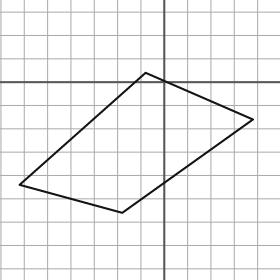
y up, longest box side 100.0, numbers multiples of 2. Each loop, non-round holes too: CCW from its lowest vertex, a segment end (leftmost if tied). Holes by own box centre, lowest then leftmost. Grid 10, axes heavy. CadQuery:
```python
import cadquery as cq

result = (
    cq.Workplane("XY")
    .moveTo(-18.0, -56.0)
    .lineTo(38.0, -16.0)
    .lineTo(-8.0, 4.0)
    .lineTo(-62.0, -44.0)
    .close()
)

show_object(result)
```